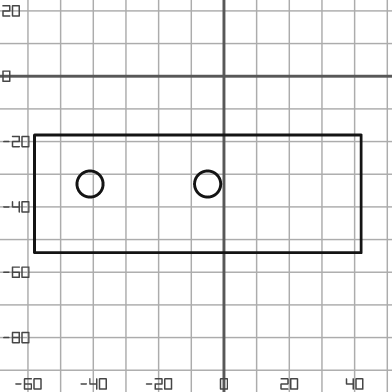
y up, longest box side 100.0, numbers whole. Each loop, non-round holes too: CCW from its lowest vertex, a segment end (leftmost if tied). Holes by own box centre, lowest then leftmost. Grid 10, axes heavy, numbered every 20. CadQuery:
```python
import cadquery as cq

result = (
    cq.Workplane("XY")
    .moveTo(-58.0, -54.0)
    .lineTo(42.0, -54.0)
    .lineTo(42.0, -18.0)
    .lineTo(-58.0, -18.0)
    .close()
    .moveTo(-41.0, -33.0)
    .circle(4.0)
    .moveTo(-5.0, -33.0)
    .circle(4.0)
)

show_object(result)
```